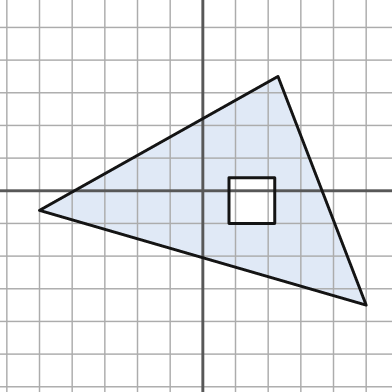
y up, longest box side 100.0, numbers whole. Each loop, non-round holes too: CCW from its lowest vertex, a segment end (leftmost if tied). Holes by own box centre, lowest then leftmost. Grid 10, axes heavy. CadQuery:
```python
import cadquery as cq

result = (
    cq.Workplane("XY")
    .moveTo(50.0, -35.0)
    .lineTo(23.0, 35.0)
    .lineTo(-50.0, -6.0)
    .close()
    .moveTo(8.0, -10.0)
    .lineTo(22.0, -10.0)
    .lineTo(22.0, 4.0)
    .lineTo(8.0, 4.0)
    .close()
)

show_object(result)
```